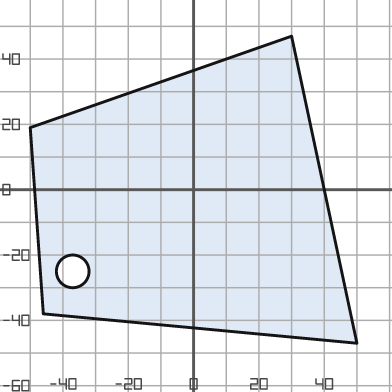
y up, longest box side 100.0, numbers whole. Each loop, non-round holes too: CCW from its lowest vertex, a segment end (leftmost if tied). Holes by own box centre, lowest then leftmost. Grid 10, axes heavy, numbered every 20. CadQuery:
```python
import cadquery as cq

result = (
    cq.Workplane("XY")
    .moveTo(50.0, -47.0)
    .lineTo(30.0, 47.0)
    .lineTo(-50.0, 19.0)
    .lineTo(-46.0, -38.0)
    .close()
    .moveTo(-37.0, -25.0)
    .circle(5.0)
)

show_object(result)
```